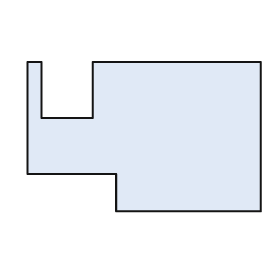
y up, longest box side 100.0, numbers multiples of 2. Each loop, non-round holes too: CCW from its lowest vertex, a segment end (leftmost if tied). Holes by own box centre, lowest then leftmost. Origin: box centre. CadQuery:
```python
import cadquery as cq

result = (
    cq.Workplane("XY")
    .moveTo(-12.0, -32.0)
    .lineTo(50.0, -32.0)
    .lineTo(50.0, 32.0)
    .lineTo(-22.0, 32.0)
    .lineTo(-22.0, 8.0)
    .lineTo(-44.0, 8.0)
    .lineTo(-44.0, 32.0)
    .lineTo(-50.0, 32.0)
    .lineTo(-50.0, -16.0)
    .lineTo(-12.0, -16.0)
    .close()
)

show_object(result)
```